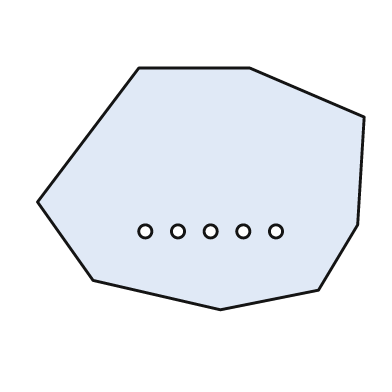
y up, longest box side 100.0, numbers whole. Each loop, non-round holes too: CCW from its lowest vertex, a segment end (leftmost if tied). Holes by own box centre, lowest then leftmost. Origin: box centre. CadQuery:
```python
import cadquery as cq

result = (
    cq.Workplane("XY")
    .moveTo(6.0, -37.0)
    .lineTo(36.0, -31.0)
    .lineTo(48.0, -11.0)
    .lineTo(50.0, 22.0)
    .lineTo(15.0, 37.0)
    .lineTo(-19.0, 37.0)
    .lineTo(-50.0, -4.0)
    .lineTo(-33.0, -28.0)
    .close()
    .moveTo(-17.0, -13.0)
    .circle(2.0)
    .moveTo(-7.0, -13.0)
    .circle(2.0)
    .moveTo(3.0, -13.0)
    .circle(2.0)
    .moveTo(13.0, -13.0)
    .circle(2.0)
    .moveTo(23.0, -13.0)
    .circle(2.0)
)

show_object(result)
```